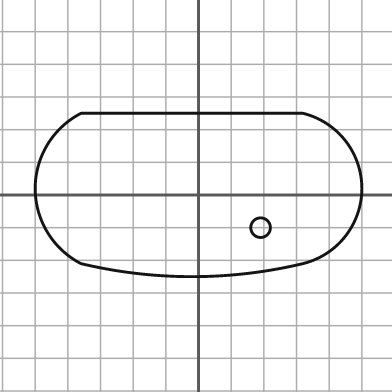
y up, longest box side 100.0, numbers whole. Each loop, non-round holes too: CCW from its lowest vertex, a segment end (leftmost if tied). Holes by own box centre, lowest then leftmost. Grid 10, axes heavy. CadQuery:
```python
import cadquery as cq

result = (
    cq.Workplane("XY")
    .moveTo(-36.0, -21.0)
    .threePointArc((-2.0, -25.0), (32.0, -21.0))
    .threePointArc((50.0, 2.0), (32.0, 25.0))
    .lineTo(-36.0, 25.0)
    .threePointArc((-50.0, 2.0), (-36.0, -21.0))
    .close()
    .moveTo(19.0, -10.0)
    .circle(3.0)
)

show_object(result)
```